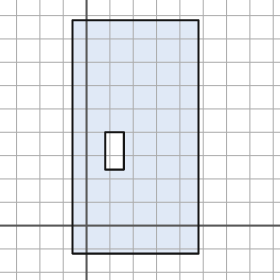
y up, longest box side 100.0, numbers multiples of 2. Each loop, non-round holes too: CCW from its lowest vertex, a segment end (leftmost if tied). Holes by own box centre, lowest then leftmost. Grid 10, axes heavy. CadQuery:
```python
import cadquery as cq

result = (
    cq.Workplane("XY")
    .moveTo(-6.0, -12.0)
    .lineTo(48.0, -12.0)
    .lineTo(48.0, 88.0)
    .lineTo(-6.0, 88.0)
    .close()
    .moveTo(8.0, 24.0)
    .lineTo(16.0, 24.0)
    .lineTo(16.0, 40.0)
    .lineTo(8.0, 40.0)
    .close()
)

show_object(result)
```